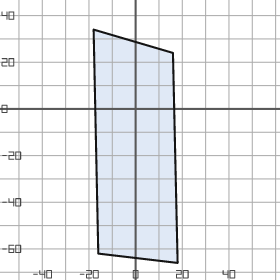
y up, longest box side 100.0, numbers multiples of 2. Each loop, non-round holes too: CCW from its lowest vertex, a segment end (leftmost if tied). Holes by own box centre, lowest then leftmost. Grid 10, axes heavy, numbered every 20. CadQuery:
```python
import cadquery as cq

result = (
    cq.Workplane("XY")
    .moveTo(18.0, -66.0)
    .lineTo(16.0, 24.0)
    .lineTo(-18.0, 34.0)
    .lineTo(-16.0, -62.0)
    .close()
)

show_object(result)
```